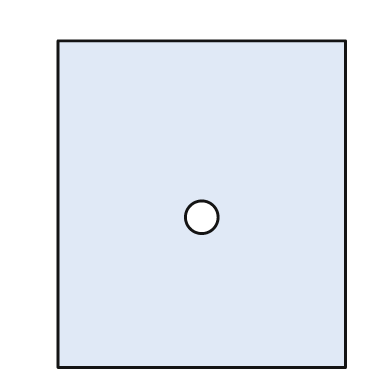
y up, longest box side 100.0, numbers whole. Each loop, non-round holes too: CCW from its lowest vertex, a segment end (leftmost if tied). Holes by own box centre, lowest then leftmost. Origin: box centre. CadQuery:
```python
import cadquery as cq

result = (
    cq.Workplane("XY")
    .moveTo(-44.0, -50.0)
    .lineTo(44.0, -50.0)
    .lineTo(44.0, 50.0)
    .lineTo(-44.0, 50.0)
    .close()
    .moveTo(0.0, -4.0)
    .circle(5.0)
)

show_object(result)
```